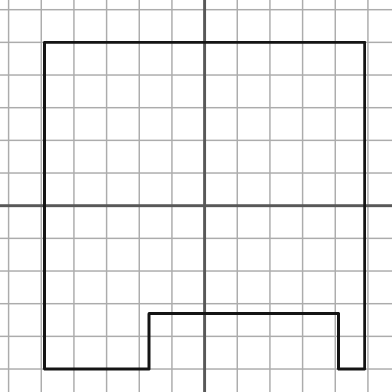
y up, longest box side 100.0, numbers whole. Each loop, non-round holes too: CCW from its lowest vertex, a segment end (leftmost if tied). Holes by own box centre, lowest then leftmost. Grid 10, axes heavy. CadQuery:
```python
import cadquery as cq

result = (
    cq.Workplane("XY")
    .moveTo(-49.0, -50.0)
    .lineTo(-17.0, -50.0)
    .lineTo(-17.0, -33.0)
    .lineTo(41.0, -33.0)
    .lineTo(41.0, -50.0)
    .lineTo(49.0, -50.0)
    .lineTo(49.0, 50.0)
    .lineTo(-49.0, 50.0)
    .close()
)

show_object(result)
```